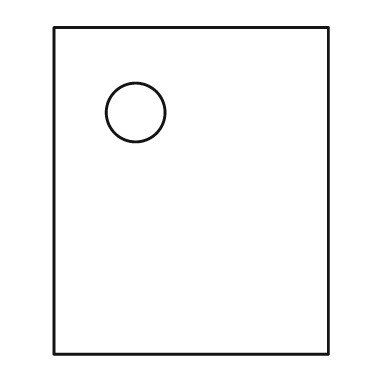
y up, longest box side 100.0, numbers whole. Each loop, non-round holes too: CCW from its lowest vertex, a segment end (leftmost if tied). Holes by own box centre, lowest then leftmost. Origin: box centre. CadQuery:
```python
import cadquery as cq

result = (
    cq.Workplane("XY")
    .moveTo(-42.0, -50.0)
    .lineTo(42.0, -50.0)
    .lineTo(42.0, 50.0)
    .lineTo(-42.0, 50.0)
    .close()
    .moveTo(-17.0, 24.0)
    .circle(9.0)
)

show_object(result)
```